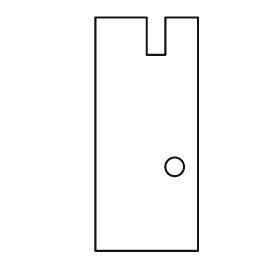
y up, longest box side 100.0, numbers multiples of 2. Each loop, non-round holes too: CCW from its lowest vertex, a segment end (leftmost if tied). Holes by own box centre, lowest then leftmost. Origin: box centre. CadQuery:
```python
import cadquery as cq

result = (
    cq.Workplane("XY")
    .moveTo(-22.0, -50.0)
    .lineTo(22.0, -50.0)
    .lineTo(22.0, 50.0)
    .lineTo(8.0, 50.0)
    .lineTo(8.0, 34.0)
    .lineTo(0.0, 34.0)
    .lineTo(0.0, 50.0)
    .lineTo(-22.0, 50.0)
    .close()
    .moveTo(12.0, -14.0)
    .circle(4.0)
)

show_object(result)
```